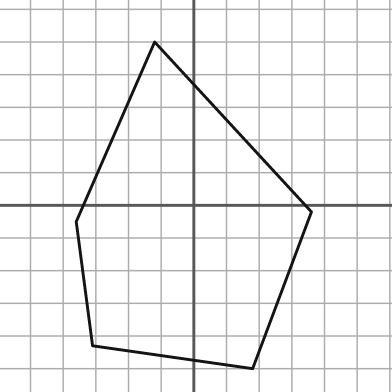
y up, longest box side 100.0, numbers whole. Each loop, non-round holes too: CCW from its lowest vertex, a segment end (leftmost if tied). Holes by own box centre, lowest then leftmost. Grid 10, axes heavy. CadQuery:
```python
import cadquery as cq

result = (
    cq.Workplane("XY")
    .moveTo(18.0, -50.0)
    .lineTo(36.0, -2.0)
    .lineTo(-12.0, 50.0)
    .lineTo(-36.0, -5.0)
    .lineTo(-31.0, -43.0)
    .close()
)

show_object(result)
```